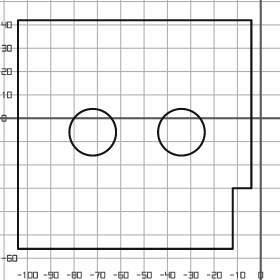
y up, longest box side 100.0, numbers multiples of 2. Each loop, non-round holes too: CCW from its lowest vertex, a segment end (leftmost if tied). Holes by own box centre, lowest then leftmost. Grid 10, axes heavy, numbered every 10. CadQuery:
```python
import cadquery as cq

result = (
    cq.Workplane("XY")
    .moveTo(-104.0, -56.0)
    .lineTo(-12.0, -56.0)
    .lineTo(-12.0, -30.0)
    .lineTo(-4.0, -30.0)
    .lineTo(-4.0, 42.0)
    .lineTo(-104.0, 42.0)
    .close()
    .moveTo(-72.0, -6.0)
    .circle(10.0)
    .moveTo(-34.0, -6.0)
    .circle(10.0)
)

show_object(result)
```